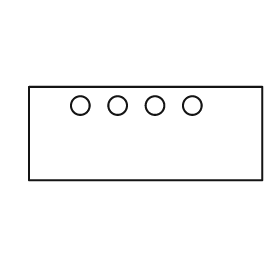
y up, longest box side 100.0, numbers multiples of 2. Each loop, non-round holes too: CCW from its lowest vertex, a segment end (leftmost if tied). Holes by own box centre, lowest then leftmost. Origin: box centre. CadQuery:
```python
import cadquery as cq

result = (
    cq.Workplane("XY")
    .moveTo(-50.0, -20.0)
    .lineTo(50.0, -20.0)
    .lineTo(50.0, 20.0)
    .lineTo(-50.0, 20.0)
    .close()
    .moveTo(-28.0, 12.0)
    .circle(4.0)
    .moveTo(-12.0, 12.0)
    .circle(4.0)
    .moveTo(4.0, 12.0)
    .circle(4.0)
    .moveTo(20.0, 12.0)
    .circle(4.0)
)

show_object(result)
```